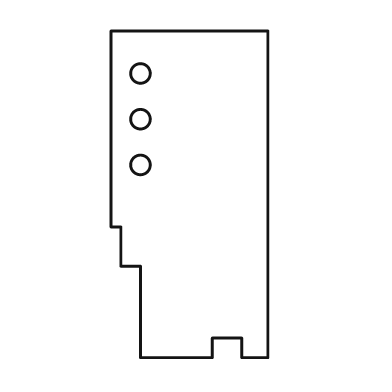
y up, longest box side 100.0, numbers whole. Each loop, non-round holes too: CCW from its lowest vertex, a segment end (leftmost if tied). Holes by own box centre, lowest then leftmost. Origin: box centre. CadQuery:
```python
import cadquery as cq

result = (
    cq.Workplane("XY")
    .moveTo(-15.0, -50.0)
    .lineTo(7.0, -50.0)
    .lineTo(7.0, -44.0)
    .lineTo(16.0, -44.0)
    .lineTo(16.0, -50.0)
    .lineTo(24.0, -50.0)
    .lineTo(24.0, 50.0)
    .lineTo(-24.0, 50.0)
    .lineTo(-24.0, -10.0)
    .lineTo(-21.0, -10.0)
    .lineTo(-21.0, -22.0)
    .lineTo(-15.0, -22.0)
    .close()
    .moveTo(-15.0, 9.0)
    .circle(3.0)
    .moveTo(-15.0, 23.0)
    .circle(3.0)
    .moveTo(-15.0, 37.0)
    .circle(3.0)
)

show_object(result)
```